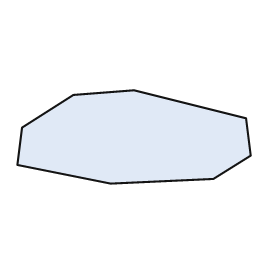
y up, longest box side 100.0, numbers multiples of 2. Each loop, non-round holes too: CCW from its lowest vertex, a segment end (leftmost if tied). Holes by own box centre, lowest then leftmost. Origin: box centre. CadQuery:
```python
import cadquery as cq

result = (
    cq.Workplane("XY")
    .moveTo(-10.0, -20.0)
    .lineTo(34.0, -18.0)
    .lineTo(50.0, -8.0)
    .lineTo(48.0, 8.0)
    .lineTo(0.0, 20.0)
    .lineTo(-26.0, 18.0)
    .lineTo(-48.0, 4.0)
    .lineTo(-50.0, -12.0)
    .close()
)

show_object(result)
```